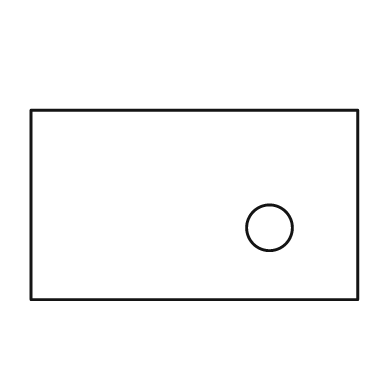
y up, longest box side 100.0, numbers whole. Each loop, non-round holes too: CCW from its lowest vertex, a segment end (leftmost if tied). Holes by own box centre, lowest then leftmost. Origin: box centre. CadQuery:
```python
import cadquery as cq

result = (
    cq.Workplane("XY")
    .moveTo(-50.0, -29.0)
    .lineTo(50.0, -29.0)
    .lineTo(50.0, 29.0)
    .lineTo(-50.0, 29.0)
    .close()
    .moveTo(23.0, -7.0)
    .circle(7.0)
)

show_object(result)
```